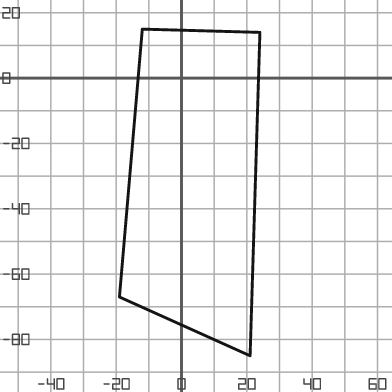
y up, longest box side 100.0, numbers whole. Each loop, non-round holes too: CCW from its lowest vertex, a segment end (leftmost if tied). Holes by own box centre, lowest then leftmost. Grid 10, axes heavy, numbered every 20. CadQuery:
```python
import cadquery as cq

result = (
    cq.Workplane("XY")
    .moveTo(21.0, -85.0)
    .lineTo(24.0, 14.0)
    .lineTo(-12.0, 15.0)
    .lineTo(-19.0, -67.0)
    .close()
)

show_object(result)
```